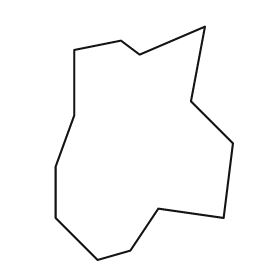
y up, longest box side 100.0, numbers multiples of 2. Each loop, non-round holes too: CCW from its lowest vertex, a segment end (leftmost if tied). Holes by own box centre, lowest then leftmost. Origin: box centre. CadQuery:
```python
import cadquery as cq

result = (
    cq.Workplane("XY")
    .moveTo(-20.0, -50.0)
    .lineTo(-6.0, -46.0)
    .lineTo(6.0, -28.0)
    .lineTo(34.0, -32.0)
    .lineTo(38.0, 0.0)
    .lineTo(20.0, 18.0)
    .lineTo(26.0, 50.0)
    .lineTo(-2.0, 38.0)
    .lineTo(-10.0, 44.0)
    .lineTo(-30.0, 40.0)
    .lineTo(-30.0, 12.0)
    .lineTo(-38.0, -10.0)
    .lineTo(-38.0, -32.0)
    .close()
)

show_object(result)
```